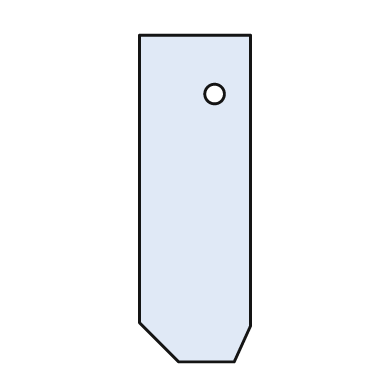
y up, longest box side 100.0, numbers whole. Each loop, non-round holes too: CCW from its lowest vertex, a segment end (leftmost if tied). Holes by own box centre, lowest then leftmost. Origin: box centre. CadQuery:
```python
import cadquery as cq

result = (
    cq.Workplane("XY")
    .moveTo(-5.0, -50.0)
    .lineTo(12.0, -50.0)
    .lineTo(17.0, -39.0)
    .lineTo(17.0, 50.0)
    .lineTo(-17.0, 50.0)
    .lineTo(-17.0, -38.0)
    .close()
    .moveTo(6.0, 32.0)
    .circle(3.0)
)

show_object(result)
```